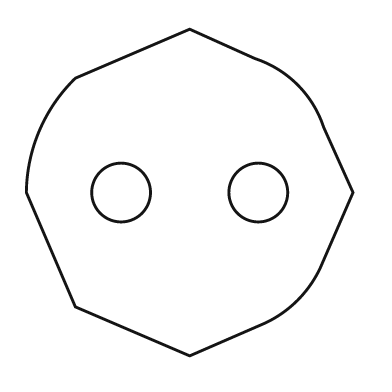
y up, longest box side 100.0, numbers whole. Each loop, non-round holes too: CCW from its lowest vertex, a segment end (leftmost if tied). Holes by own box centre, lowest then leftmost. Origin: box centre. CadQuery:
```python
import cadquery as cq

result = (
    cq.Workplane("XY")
    .moveTo(0.0, -50.0)
    .lineTo(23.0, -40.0)
    .threePointArc((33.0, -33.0), (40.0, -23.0))
    .lineTo(50.0, 0.0)
    .lineTo(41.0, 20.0)
    .threePointArc((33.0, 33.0), (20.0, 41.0))
    .lineTo(0.0, 50.0)
    .lineTo(-35.0, 35.0)
    .threePointArc((-46.0, 19.0), (-50.0, 0.0))
    .lineTo(-35.0, -35.0)
    .close()
    .moveTo(-21.0, 0.0)
    .circle(9.0)
    .moveTo(21.0, 0.0)
    .circle(9.0)
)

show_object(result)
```